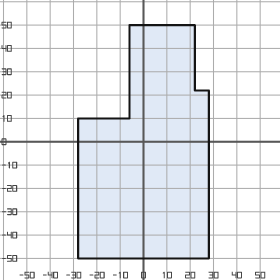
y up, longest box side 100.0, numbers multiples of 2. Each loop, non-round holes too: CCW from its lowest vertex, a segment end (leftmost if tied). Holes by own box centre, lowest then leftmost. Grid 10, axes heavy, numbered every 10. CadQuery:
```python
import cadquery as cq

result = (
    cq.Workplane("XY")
    .moveTo(-28.0, -50.0)
    .lineTo(28.0, -50.0)
    .lineTo(28.0, 22.0)
    .lineTo(22.0, 22.0)
    .lineTo(22.0, 50.0)
    .lineTo(-6.0, 50.0)
    .lineTo(-6.0, 10.0)
    .lineTo(-28.0, 10.0)
    .close()
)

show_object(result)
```